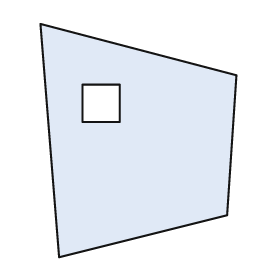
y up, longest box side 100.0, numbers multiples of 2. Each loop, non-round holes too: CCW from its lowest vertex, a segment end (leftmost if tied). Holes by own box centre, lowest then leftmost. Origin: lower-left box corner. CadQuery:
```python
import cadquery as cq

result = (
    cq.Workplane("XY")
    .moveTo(8.0, 0.0)
    .lineTo(80.0, 18.0)
    .lineTo(84.0, 78.0)
    .lineTo(0.0, 100.0)
    .close()
    .moveTo(18.0, 58.0)
    .lineTo(34.0, 58.0)
    .lineTo(34.0, 74.0)
    .lineTo(18.0, 74.0)
    .close()
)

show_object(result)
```